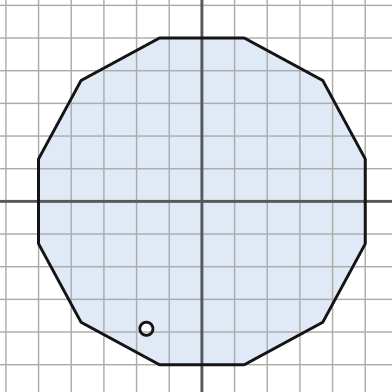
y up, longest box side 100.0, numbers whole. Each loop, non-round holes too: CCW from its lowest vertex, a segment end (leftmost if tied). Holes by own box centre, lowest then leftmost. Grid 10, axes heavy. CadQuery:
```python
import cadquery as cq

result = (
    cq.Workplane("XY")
    .moveTo(-13.0, -50.0)
    .lineTo(13.0, -50.0)
    .lineTo(37.0, -37.0)
    .lineTo(50.0, -13.0)
    .lineTo(50.0, 13.0)
    .lineTo(37.0, 37.0)
    .lineTo(13.0, 50.0)
    .lineTo(-13.0, 50.0)
    .lineTo(-37.0, 37.0)
    .lineTo(-50.0, 13.0)
    .lineTo(-50.0, -13.0)
    .lineTo(-37.0, -37.0)
    .close()
    .moveTo(-17.0, -39.0)
    .circle(2.0)
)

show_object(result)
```